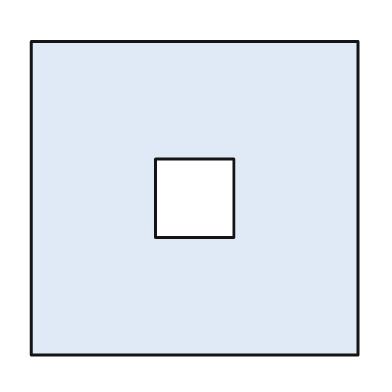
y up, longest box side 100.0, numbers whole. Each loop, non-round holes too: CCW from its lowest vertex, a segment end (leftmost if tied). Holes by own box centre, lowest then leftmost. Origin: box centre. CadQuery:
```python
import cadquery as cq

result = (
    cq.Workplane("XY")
    .moveTo(-50.0, -48.0)
    .lineTo(50.0, -48.0)
    .lineTo(50.0, 48.0)
    .lineTo(-50.0, 48.0)
    .close()
    .moveTo(-12.0, -12.0)
    .lineTo(12.0, -12.0)
    .lineTo(12.0, 12.0)
    .lineTo(-12.0, 12.0)
    .close()
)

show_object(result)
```